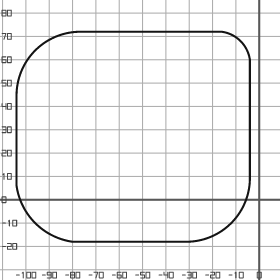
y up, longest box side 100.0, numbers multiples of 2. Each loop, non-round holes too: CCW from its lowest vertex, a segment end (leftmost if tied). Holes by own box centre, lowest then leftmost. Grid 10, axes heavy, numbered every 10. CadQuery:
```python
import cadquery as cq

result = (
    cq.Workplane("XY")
    .moveTo(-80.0, -18.0)
    .lineTo(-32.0, -18.0)
    .threePointArc((-12.0, -10.0), (-4.0, 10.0))
    .lineTo(-4.0, 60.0)
    .threePointArc((-8.0, 68.0), (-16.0, 72.0))
    .lineTo(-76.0, 72.0)
    .threePointArc((-96.0, 64.0), (-104.0, 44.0))
    .lineTo(-104.0, 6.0)
    .threePointArc((-96.0, -10.0), (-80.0, -18.0))
    .close()
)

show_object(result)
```